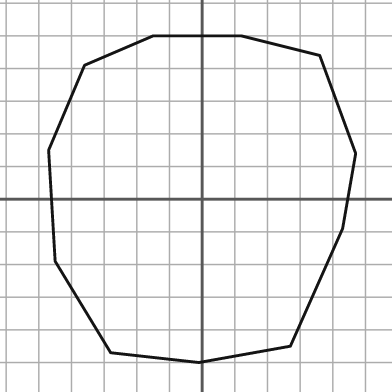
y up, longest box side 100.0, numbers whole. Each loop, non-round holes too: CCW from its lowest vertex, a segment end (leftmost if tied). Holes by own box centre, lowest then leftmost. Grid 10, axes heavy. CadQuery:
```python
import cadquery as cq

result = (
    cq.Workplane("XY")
    .moveTo(-1.0, -50.0)
    .lineTo(27.0, -45.0)
    .lineTo(43.0, -9.0)
    .lineTo(47.0, 14.0)
    .lineTo(36.0, 44.0)
    .lineTo(12.0, 50.0)
    .lineTo(-15.0, 50.0)
    .lineTo(-36.0, 41.0)
    .lineTo(-47.0, 15.0)
    .lineTo(-45.0, -19.0)
    .lineTo(-28.0, -47.0)
    .close()
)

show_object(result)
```